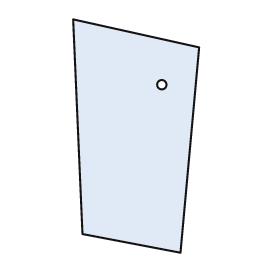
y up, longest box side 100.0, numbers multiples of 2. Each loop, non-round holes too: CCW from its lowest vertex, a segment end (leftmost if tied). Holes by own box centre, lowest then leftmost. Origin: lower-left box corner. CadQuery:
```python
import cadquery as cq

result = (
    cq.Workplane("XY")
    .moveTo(46.0, 0.0)
    .lineTo(54.0, 88.0)
    .lineTo(0.0, 100.0)
    .lineTo(4.0, 8.0)
    .close()
    .moveTo(38.0, 72.0)
    .circle(2.0)
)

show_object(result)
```